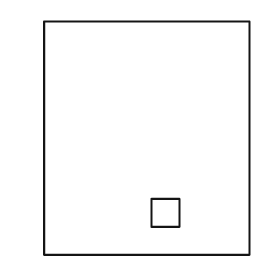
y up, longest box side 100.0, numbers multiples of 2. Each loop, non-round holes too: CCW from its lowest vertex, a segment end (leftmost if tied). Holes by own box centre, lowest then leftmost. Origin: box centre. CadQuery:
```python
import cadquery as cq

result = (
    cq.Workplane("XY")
    .moveTo(-44.0, -50.0)
    .lineTo(44.0, -50.0)
    .lineTo(44.0, 50.0)
    .lineTo(-44.0, 50.0)
    .close()
    .moveTo(2.0, -38.0)
    .lineTo(14.0, -38.0)
    .lineTo(14.0, -26.0)
    .lineTo(2.0, -26.0)
    .close()
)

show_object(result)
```